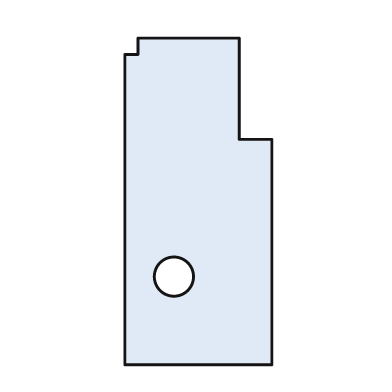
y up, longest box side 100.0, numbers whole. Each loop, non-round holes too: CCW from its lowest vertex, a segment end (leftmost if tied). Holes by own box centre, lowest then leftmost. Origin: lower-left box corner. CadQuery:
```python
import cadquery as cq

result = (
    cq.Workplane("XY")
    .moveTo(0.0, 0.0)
    .lineTo(45.0, 0.0)
    .lineTo(45.0, 69.0)
    .lineTo(35.0, 69.0)
    .lineTo(35.0, 100.0)
    .lineTo(4.0, 100.0)
    .lineTo(4.0, 95.0)
    .lineTo(0.0, 95.0)
    .close()
    .moveTo(15.0, 27.0)
    .circle(6.0)
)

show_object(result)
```